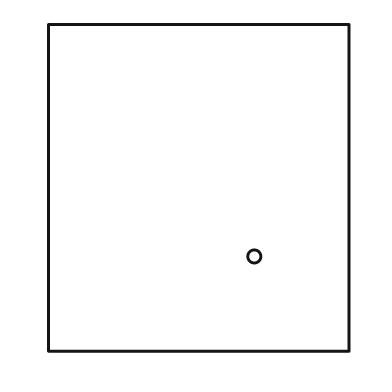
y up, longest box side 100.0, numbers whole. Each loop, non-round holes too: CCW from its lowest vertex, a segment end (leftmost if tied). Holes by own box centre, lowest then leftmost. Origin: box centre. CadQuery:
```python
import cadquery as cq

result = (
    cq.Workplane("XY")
    .moveTo(-46.0, -50.0)
    .lineTo(46.0, -50.0)
    .lineTo(46.0, 50.0)
    .lineTo(-46.0, 50.0)
    .close()
    .moveTo(17.0, -21.0)
    .circle(2.0)
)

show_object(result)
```